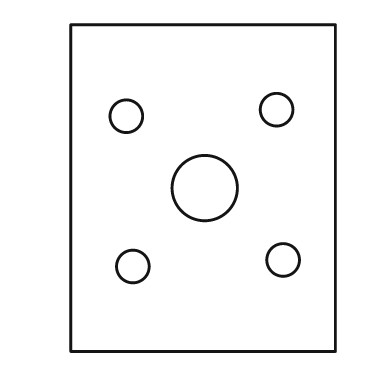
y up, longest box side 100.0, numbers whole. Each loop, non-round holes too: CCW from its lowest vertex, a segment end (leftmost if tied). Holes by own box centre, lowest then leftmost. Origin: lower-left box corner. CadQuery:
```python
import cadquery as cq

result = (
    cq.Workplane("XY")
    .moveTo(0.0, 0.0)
    .lineTo(81.0, 0.0)
    .lineTo(81.0, 100.0)
    .lineTo(0.0, 100.0)
    .close()
    .moveTo(19.0, 26.0)
    .circle(5.0)
    .moveTo(65.0, 28.0)
    .circle(5.0)
    .moveTo(41.0, 50.0)
    .circle(10.0)
    .moveTo(17.0, 72.0)
    .circle(5.0)
    .moveTo(63.0, 74.0)
    .circle(5.0)
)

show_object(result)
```